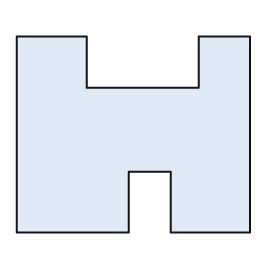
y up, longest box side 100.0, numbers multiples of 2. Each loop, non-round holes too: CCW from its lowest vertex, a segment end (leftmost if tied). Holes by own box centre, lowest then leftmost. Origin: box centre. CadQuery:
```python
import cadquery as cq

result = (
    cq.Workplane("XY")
    .moveTo(-50.0, -42.0)
    .lineTo(-2.0, -42.0)
    .lineTo(-2.0, -16.0)
    .lineTo(16.0, -16.0)
    .lineTo(16.0, -42.0)
    .lineTo(50.0, -42.0)
    .lineTo(50.0, 42.0)
    .lineTo(28.0, 42.0)
    .lineTo(28.0, 20.0)
    .lineTo(-20.0, 20.0)
    .lineTo(-20.0, 42.0)
    .lineTo(-50.0, 42.0)
    .close()
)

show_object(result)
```